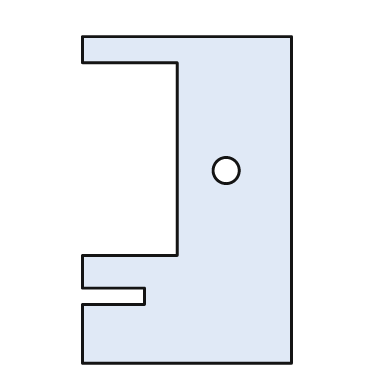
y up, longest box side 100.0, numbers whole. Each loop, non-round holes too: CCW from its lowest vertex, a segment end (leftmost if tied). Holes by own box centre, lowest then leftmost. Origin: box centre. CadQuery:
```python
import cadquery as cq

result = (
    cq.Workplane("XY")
    .moveTo(-32.0, -50.0)
    .lineTo(32.0, -50.0)
    .lineTo(32.0, 50.0)
    .lineTo(-32.0, 50.0)
    .lineTo(-32.0, 42.0)
    .lineTo(-3.0, 42.0)
    .lineTo(-3.0, -17.0)
    .lineTo(-32.0, -17.0)
    .lineTo(-32.0, -27.0)
    .lineTo(-13.0, -27.0)
    .lineTo(-13.0, -32.0)
    .lineTo(-32.0, -32.0)
    .close()
    .moveTo(12.0, 9.0)
    .circle(4.0)
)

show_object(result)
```